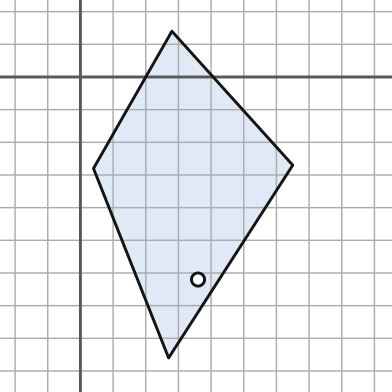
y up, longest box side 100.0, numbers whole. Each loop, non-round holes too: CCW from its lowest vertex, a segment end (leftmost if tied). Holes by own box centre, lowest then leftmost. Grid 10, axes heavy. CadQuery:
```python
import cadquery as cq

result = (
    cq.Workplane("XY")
    .moveTo(27.0, -86.0)
    .lineTo(65.0, -27.0)
    .lineTo(28.0, 14.0)
    .lineTo(4.0, -28.0)
    .close()
    .moveTo(36.0, -62.0)
    .circle(2.0)
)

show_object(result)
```